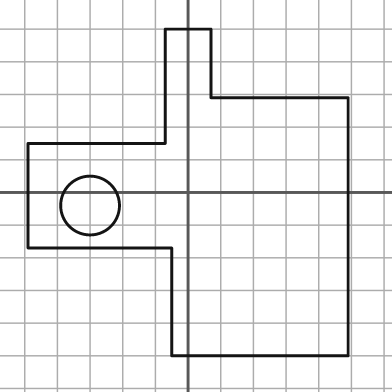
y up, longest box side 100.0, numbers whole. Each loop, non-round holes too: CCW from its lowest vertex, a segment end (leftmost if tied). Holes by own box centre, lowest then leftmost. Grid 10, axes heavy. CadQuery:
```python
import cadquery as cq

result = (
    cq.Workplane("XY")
    .moveTo(-5.0, -50.0)
    .lineTo(49.0, -50.0)
    .lineTo(49.0, 29.0)
    .lineTo(7.0, 29.0)
    .lineTo(7.0, 50.0)
    .lineTo(-7.0, 50.0)
    .lineTo(-7.0, 15.0)
    .lineTo(-49.0, 15.0)
    .lineTo(-49.0, -17.0)
    .lineTo(-5.0, -17.0)
    .close()
    .moveTo(-30.0, -4.0)
    .circle(9.0)
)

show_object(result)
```